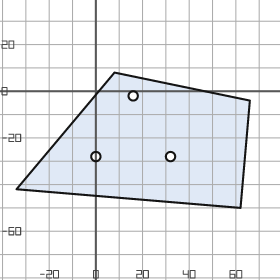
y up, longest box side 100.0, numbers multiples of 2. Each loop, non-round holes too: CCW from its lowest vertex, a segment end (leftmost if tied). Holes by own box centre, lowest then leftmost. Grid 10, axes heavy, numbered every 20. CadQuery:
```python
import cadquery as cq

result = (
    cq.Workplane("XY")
    .moveTo(62.0, -50.0)
    .lineTo(66.0, -4.0)
    .lineTo(8.0, 8.0)
    .lineTo(-34.0, -42.0)
    .close()
    .moveTo(0.0, -28.0)
    .circle(2.0)
    .moveTo(32.0, -28.0)
    .circle(2.0)
    .moveTo(16.0, -2.0)
    .circle(2.0)
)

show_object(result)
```